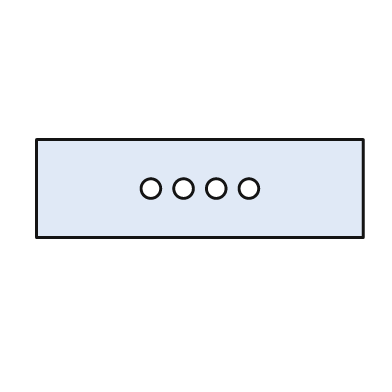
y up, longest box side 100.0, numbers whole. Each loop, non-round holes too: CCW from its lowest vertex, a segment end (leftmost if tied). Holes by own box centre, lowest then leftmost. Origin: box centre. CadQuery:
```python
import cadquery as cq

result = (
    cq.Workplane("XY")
    .moveTo(-50.0, -15.0)
    .lineTo(50.0, -15.0)
    .lineTo(50.0, 15.0)
    .lineTo(-50.0, 15.0)
    .close()
    .moveTo(-15.0, 0.0)
    .circle(3.0)
    .moveTo(-5.0, 0.0)
    .circle(3.0)
    .moveTo(5.0, 0.0)
    .circle(3.0)
    .moveTo(15.0, 0.0)
    .circle(3.0)
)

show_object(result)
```